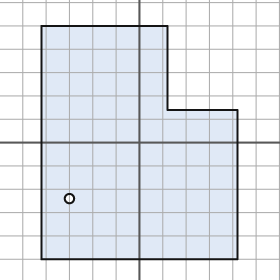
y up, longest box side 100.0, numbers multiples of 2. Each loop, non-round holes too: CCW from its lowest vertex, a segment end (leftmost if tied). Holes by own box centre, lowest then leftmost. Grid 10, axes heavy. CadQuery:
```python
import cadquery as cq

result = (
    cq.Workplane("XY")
    .moveTo(-42.0, -50.0)
    .lineTo(42.0, -50.0)
    .lineTo(42.0, 14.0)
    .lineTo(12.0, 14.0)
    .lineTo(12.0, 50.0)
    .lineTo(-42.0, 50.0)
    .close()
    .moveTo(-30.0, -24.0)
    .circle(2.0)
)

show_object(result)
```